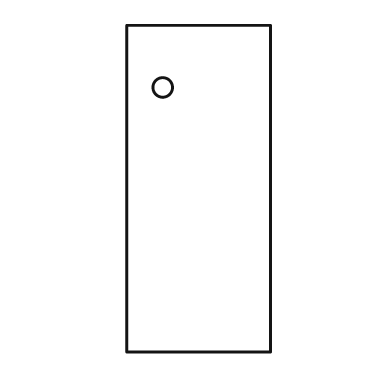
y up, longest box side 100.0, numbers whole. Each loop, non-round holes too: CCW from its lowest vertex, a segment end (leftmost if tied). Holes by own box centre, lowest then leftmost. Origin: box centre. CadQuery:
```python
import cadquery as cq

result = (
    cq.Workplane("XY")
    .moveTo(-22.0, -50.0)
    .lineTo(22.0, -50.0)
    .lineTo(22.0, 50.0)
    .lineTo(-22.0, 50.0)
    .close()
    .moveTo(-11.0, 31.0)
    .circle(3.0)
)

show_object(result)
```